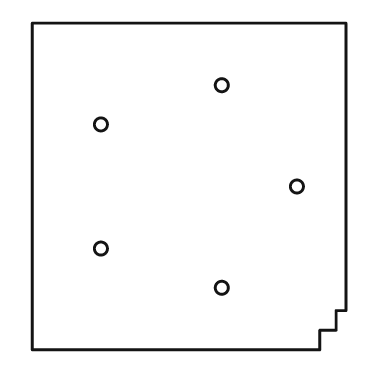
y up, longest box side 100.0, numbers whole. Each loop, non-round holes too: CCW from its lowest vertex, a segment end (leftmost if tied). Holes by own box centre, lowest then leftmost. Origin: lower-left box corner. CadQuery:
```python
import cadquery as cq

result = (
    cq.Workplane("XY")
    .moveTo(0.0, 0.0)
    .lineTo(88.0, 0.0)
    .lineTo(88.0, 6.0)
    .lineTo(93.0, 6.0)
    .lineTo(93.0, 12.0)
    .lineTo(96.0, 12.0)
    .lineTo(96.0, 100.0)
    .lineTo(0.0, 100.0)
    .close()
    .moveTo(58.0, 19.0)
    .circle(2.0)
    .moveTo(21.0, 31.0)
    .circle(2.0)
    .moveTo(81.0, 50.0)
    .circle(2.0)
    .moveTo(21.0, 69.0)
    .circle(2.0)
    .moveTo(58.0, 81.0)
    .circle(2.0)
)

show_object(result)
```